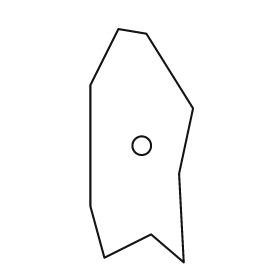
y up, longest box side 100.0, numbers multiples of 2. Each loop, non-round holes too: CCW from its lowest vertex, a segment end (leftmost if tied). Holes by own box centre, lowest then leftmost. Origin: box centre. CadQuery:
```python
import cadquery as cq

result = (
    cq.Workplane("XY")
    .moveTo(18.0, -50.0)
    .lineTo(16.0, -12.0)
    .lineTo(22.0, 16.0)
    .lineTo(2.0, 48.0)
    .lineTo(-10.0, 50.0)
    .lineTo(-22.0, 26.0)
    .lineTo(-22.0, -26.0)
    .lineTo(-16.0, -48.0)
    .lineTo(4.0, -38.0)
    .close()
    .moveTo(0.0, 0.0)
    .circle(4.0)
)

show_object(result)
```